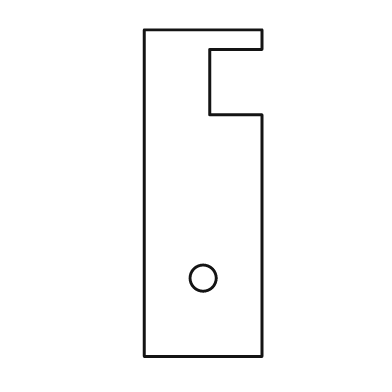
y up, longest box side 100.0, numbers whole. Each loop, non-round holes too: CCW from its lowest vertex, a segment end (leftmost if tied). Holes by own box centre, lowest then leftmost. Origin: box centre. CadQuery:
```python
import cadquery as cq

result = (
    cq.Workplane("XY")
    .moveTo(-18.0, -50.0)
    .lineTo(18.0, -50.0)
    .lineTo(18.0, 24.0)
    .lineTo(2.0, 24.0)
    .lineTo(2.0, 44.0)
    .lineTo(18.0, 44.0)
    .lineTo(18.0, 50.0)
    .lineTo(-18.0, 50.0)
    .close()
    .moveTo(0.0, -26.0)
    .circle(4.0)
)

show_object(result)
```